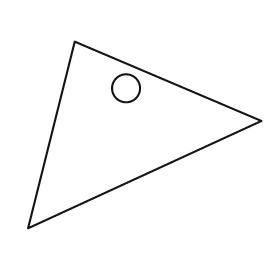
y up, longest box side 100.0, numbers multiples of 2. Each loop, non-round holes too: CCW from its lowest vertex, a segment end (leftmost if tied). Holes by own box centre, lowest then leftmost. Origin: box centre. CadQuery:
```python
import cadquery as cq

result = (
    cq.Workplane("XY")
    .moveTo(-50.0, -40.0)
    .lineTo(50.0, 6.0)
    .lineTo(-30.0, 40.0)
    .close()
    .moveTo(-8.0, 20.0)
    .circle(6.0)
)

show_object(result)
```